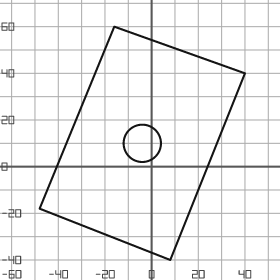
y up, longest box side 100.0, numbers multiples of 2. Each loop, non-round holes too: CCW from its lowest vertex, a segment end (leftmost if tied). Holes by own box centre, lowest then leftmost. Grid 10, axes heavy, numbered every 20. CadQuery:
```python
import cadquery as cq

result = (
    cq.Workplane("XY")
    .moveTo(8.0, -40.0)
    .lineTo(40.0, 40.0)
    .lineTo(-16.0, 60.0)
    .lineTo(-48.0, -18.0)
    .close()
    .moveTo(-4.0, 10.0)
    .circle(8.0)
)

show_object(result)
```